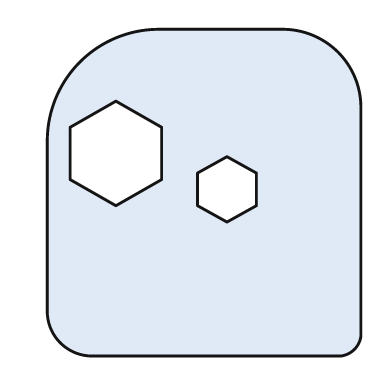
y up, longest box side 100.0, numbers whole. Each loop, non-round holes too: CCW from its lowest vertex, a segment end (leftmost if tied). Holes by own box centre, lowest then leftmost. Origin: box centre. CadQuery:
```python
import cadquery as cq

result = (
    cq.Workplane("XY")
    .moveTo(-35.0, -50.0)
    .lineTo(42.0, -50.0)
    .threePointArc((46.0, -48.0), (48.0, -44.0))
    .lineTo(48.0, 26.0)
    .threePointArc((41.0, 43.0), (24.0, 50.0))
    .lineTo(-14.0, 50.0)
    .threePointArc((-38.0, 40.0), (-48.0, 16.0))
    .lineTo(-48.0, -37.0)
    .threePointArc((-44.0, -46.0), (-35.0, -50.0))
    .close()
    .moveTo(7.0, -9.0)
    .lineTo(16.0, -4.0)
    .lineTo(16.0, 6.0)
    .lineTo(7.0, 11.0)
    .lineTo(-2.0, 6.0)
    .lineTo(-2.0, -4.0)
    .close()
    .moveTo(-27.0, -4.0)
    .lineTo(-13.0, 4.0)
    .lineTo(-13.0, 20.0)
    .lineTo(-27.0, 28.0)
    .lineTo(-41.0, 20.0)
    .lineTo(-41.0, 4.0)
    .close()
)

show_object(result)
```